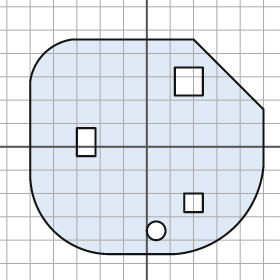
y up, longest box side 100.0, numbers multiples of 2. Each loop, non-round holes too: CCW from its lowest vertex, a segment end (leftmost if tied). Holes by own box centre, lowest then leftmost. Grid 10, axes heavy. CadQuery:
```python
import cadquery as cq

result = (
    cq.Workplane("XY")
    .moveTo(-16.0, -46.0)
    .lineTo(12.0, -46.0)
    .threePointArc((38.0, -34.0), (50.0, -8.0))
    .lineTo(50.0, 16.0)
    .lineTo(20.0, 46.0)
    .lineTo(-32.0, 46.0)
    .threePointArc((-44.0, 40.0), (-50.0, 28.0))
    .lineTo(-50.0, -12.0)
    .threePointArc((-40.0, -36.0), (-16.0, -46.0))
    .close()
    .moveTo(4.0, -36.0)
    .circle(4.0)
    .moveTo(16.0, -28.0)
    .lineTo(24.0, -28.0)
    .lineTo(24.0, -20.0)
    .lineTo(16.0, -20.0)
    .close()
    .moveTo(-30.0, -4.0)
    .lineTo(-22.0, -4.0)
    .lineTo(-22.0, 8.0)
    .lineTo(-30.0, 8.0)
    .close()
    .moveTo(12.0, 22.0)
    .lineTo(24.0, 22.0)
    .lineTo(24.0, 34.0)
    .lineTo(12.0, 34.0)
    .close()
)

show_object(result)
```